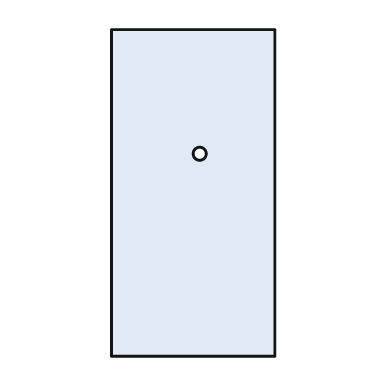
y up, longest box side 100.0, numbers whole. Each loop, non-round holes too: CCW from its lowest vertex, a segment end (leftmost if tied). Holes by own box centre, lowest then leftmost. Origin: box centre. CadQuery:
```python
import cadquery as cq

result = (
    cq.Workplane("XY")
    .moveTo(-25.0, -50.0)
    .lineTo(25.0, -50.0)
    .lineTo(25.0, 50.0)
    .lineTo(-25.0, 50.0)
    .close()
    .moveTo(2.0, 12.0)
    .circle(2.0)
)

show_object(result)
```